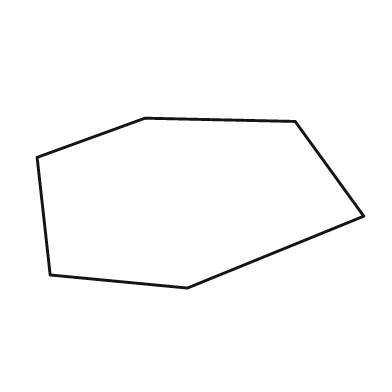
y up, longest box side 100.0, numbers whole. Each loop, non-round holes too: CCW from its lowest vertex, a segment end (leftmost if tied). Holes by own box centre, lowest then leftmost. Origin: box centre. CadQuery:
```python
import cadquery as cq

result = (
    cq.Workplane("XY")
    .moveTo(-4.0, -26.0)
    .lineTo(50.0, -4.0)
    .lineTo(29.0, 25.0)
    .lineTo(-17.0, 26.0)
    .lineTo(-50.0, 14.0)
    .lineTo(-46.0, -22.0)
    .close()
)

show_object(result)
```